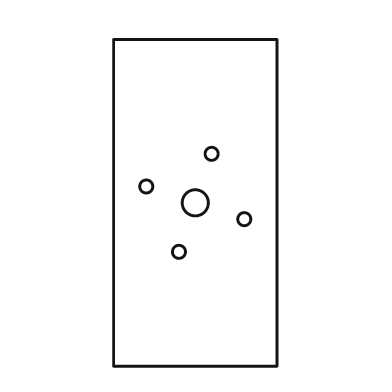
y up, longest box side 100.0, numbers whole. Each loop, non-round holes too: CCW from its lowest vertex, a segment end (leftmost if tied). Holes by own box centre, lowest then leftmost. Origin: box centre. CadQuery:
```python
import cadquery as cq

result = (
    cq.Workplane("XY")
    .moveTo(-25.0, -50.0)
    .lineTo(25.0, -50.0)
    .lineTo(25.0, 50.0)
    .lineTo(-25.0, 50.0)
    .close()
    .moveTo(-5.0, -15.0)
    .circle(2.0)
    .moveTo(15.0, -5.0)
    .circle(2.0)
    .moveTo(0.0, 0.0)
    .circle(4.0)
    .moveTo(-15.0, 5.0)
    .circle(2.0)
    .moveTo(5.0, 15.0)
    .circle(2.0)
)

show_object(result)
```